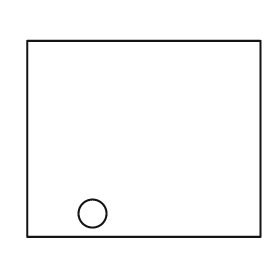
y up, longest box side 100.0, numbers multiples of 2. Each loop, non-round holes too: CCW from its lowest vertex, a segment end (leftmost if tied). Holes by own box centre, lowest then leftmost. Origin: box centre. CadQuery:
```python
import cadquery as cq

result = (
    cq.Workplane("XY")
    .moveTo(-50.0, -42.0)
    .lineTo(50.0, -42.0)
    .lineTo(50.0, 42.0)
    .lineTo(-50.0, 42.0)
    .close()
    .moveTo(-22.0, -32.0)
    .circle(6.0)
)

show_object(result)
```